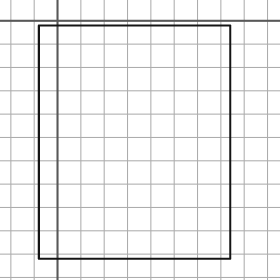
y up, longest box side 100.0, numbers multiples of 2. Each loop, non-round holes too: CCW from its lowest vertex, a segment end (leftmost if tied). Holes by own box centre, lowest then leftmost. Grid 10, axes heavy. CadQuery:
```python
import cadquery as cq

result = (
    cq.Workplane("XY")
    .moveTo(-8.0, -102.0)
    .lineTo(74.0, -102.0)
    .lineTo(74.0, -2.0)
    .lineTo(-8.0, -2.0)
    .close()
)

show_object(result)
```